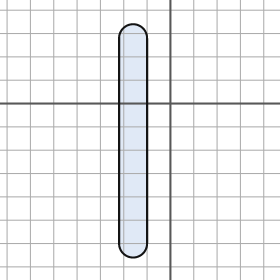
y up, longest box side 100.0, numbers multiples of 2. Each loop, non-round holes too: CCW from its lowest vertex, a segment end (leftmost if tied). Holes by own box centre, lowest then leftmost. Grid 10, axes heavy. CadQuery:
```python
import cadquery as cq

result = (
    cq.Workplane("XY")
    .moveTo(-22.0, -60.0)
    .threePointArc((-16.0, -66.0), (-10.0, -60.0))
    .lineTo(-10.0, 28.0)
    .threePointArc((-16.0, 34.0), (-22.0, 28.0))
    .close()
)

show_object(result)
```